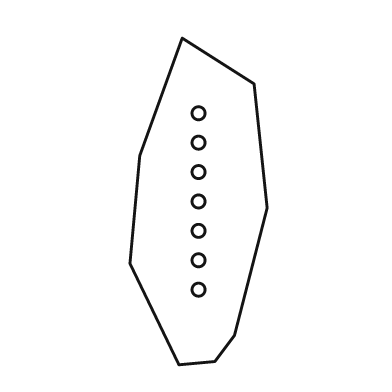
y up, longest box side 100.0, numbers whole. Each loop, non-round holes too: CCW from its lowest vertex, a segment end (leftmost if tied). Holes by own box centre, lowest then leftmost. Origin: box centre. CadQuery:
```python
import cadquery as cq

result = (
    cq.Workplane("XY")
    .moveTo(-6.0, -50.0)
    .lineTo(5.0, -49.0)
    .lineTo(11.0, -41.0)
    .lineTo(21.0, -2.0)
    .lineTo(17.0, 36.0)
    .lineTo(-5.0, 50.0)
    .lineTo(-18.0, 14.0)
    .lineTo(-21.0, -19.0)
    .close()
    .moveTo(0.0, -27.0)
    .circle(2.0)
    .moveTo(0.0, -18.0)
    .circle(2.0)
    .moveTo(0.0, -9.0)
    .circle(2.0)
    .moveTo(0.0, 0.0)
    .circle(2.0)
    .moveTo(0.0, 9.0)
    .circle(2.0)
    .moveTo(0.0, 18.0)
    .circle(2.0)
    .moveTo(0.0, 27.0)
    .circle(2.0)
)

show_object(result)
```